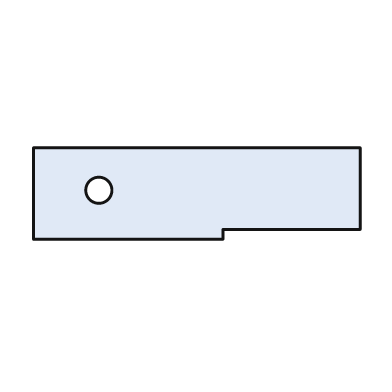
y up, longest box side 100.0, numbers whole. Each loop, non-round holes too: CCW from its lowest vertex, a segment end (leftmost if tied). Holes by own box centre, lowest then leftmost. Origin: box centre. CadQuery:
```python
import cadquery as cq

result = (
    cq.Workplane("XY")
    .moveTo(-50.0, -14.0)
    .lineTo(8.0, -14.0)
    .lineTo(8.0, -11.0)
    .lineTo(50.0, -11.0)
    .lineTo(50.0, 14.0)
    .lineTo(-50.0, 14.0)
    .close()
    .moveTo(-30.0, 1.0)
    .circle(4.0)
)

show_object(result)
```